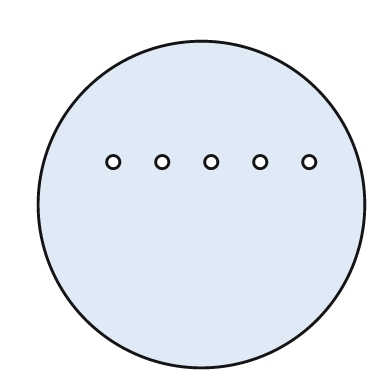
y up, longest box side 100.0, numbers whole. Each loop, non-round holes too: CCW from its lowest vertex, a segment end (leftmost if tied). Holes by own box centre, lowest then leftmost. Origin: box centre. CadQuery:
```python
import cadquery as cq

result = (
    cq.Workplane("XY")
    .moveTo(0.0, 0.0)
    .circle(50.0)
    .moveTo(-27.0, 13.0)
    .circle(2.0)
    .moveTo(-12.0, 13.0)
    .circle(2.0)
    .moveTo(3.0, 13.0)
    .circle(2.0)
    .moveTo(18.0, 13.0)
    .circle(2.0)
    .moveTo(33.0, 13.0)
    .circle(2.0)
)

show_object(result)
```